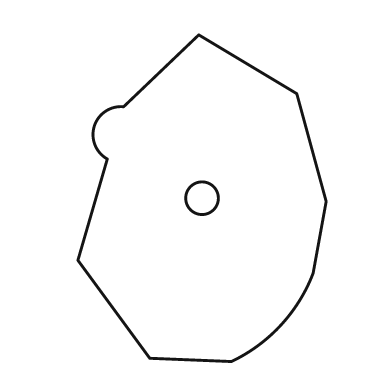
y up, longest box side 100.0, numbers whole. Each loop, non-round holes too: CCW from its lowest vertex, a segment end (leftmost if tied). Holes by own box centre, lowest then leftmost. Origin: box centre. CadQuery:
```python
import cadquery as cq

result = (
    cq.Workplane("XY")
    .moveTo(9.0, -50.0)
    .threePointArc((24.0, -39.0), (34.0, -23.0))
    .lineTo(38.0, -1.0)
    .lineTo(29.0, 32.0)
    .lineTo(-1.0, 50.0)
    .lineTo(-24.0, 28.0)
    .threePointArc((-33.0, 22.0), (-29.0, 12.0))
    .lineTo(-38.0, -19.0)
    .lineTo(-16.0, -49.0)
    .close()
    .moveTo(0.0, 0.0)
    .circle(5.0)
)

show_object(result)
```